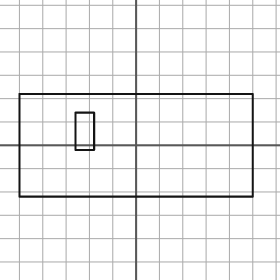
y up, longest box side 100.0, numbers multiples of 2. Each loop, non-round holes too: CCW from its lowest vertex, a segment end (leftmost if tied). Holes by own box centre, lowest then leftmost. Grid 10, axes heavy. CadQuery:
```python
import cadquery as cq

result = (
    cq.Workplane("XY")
    .moveTo(-50.0, -22.0)
    .lineTo(50.0, -22.0)
    .lineTo(50.0, 22.0)
    .lineTo(-50.0, 22.0)
    .close()
    .moveTo(-26.0, -2.0)
    .lineTo(-18.0, -2.0)
    .lineTo(-18.0, 14.0)
    .lineTo(-26.0, 14.0)
    .close()
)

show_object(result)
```